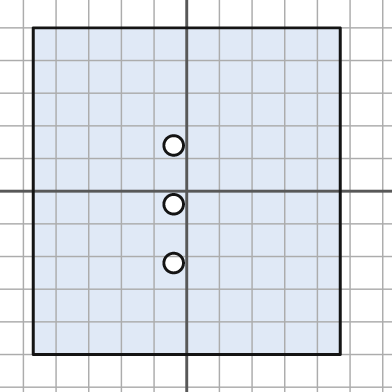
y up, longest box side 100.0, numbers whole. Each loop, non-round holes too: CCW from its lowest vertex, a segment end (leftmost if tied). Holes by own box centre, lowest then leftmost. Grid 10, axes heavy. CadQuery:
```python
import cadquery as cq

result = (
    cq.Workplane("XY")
    .moveTo(-47.0, -50.0)
    .lineTo(47.0, -50.0)
    .lineTo(47.0, 50.0)
    .lineTo(-47.0, 50.0)
    .close()
    .moveTo(-4.0, -22.0)
    .circle(3.0)
    .moveTo(-4.0, -4.0)
    .circle(3.0)
    .moveTo(-4.0, 14.0)
    .circle(3.0)
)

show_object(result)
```